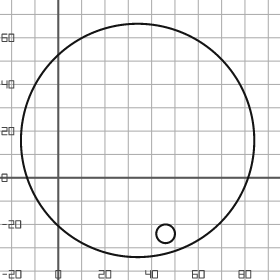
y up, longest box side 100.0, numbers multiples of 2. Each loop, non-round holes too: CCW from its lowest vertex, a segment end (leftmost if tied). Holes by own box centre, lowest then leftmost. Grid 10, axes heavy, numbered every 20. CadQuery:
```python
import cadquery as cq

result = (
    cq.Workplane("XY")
    .moveTo(34.0, 16.0)
    .circle(50.0)
    .moveTo(46.0, -24.0)
    .circle(4.0)
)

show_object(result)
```